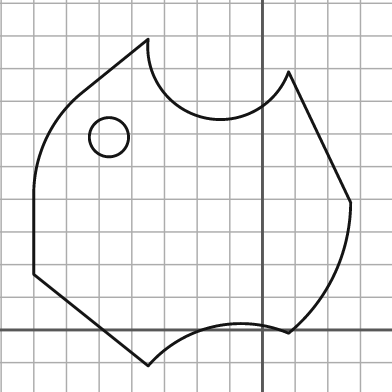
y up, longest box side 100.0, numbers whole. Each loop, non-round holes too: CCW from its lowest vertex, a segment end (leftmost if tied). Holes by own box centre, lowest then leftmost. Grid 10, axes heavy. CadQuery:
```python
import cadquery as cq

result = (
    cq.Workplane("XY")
    .moveTo(-35.0, -11.0)
    .threePointArc((-15.0, 1.0), (8.0, -1.0))
    .threePointArc((22.0, 17.0), (27.0, 39.0))
    .lineTo(8.0, 79.0)
    .threePointArc((-18.0, 65.0), (-35.0, 89.0))
    .lineTo(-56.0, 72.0)
    .threePointArc((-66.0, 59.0), (-70.0, 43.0))
    .lineTo(-70.0, 17.0)
    .close()
    .moveTo(-47.0, 59.0)
    .circle(6.0)
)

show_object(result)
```